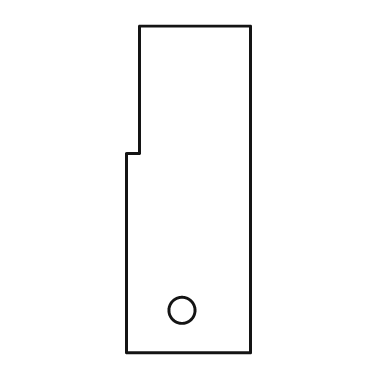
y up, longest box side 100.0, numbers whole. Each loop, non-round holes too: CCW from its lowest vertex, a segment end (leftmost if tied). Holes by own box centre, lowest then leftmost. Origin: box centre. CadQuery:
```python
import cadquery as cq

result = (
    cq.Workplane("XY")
    .moveTo(-19.0, -50.0)
    .lineTo(19.0, -50.0)
    .lineTo(19.0, 50.0)
    .lineTo(-15.0, 50.0)
    .lineTo(-15.0, 11.0)
    .lineTo(-19.0, 11.0)
    .close()
    .moveTo(-2.0, -37.0)
    .circle(4.0)
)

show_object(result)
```